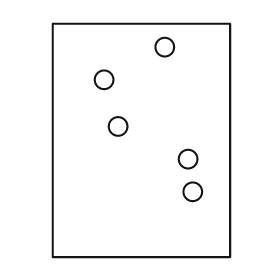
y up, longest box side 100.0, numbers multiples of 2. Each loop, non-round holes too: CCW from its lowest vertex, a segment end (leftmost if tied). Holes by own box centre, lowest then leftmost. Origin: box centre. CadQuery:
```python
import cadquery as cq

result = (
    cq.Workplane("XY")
    .moveTo(-38.0, -50.0)
    .lineTo(38.0, -50.0)
    .lineTo(38.0, 50.0)
    .lineTo(-38.0, 50.0)
    .close()
    .moveTo(22.0, -22.0)
    .circle(4.0)
    .moveTo(20.0, -8.0)
    .circle(4.0)
    .moveTo(-10.0, 6.0)
    .circle(4.0)
    .moveTo(-16.0, 26.0)
    .circle(4.0)
    .moveTo(10.0, 40.0)
    .circle(4.0)
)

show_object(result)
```